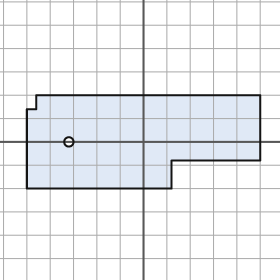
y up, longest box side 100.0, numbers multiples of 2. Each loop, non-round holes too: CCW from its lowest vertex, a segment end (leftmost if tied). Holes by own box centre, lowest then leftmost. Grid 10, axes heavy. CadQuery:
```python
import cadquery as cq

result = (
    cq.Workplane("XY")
    .moveTo(-50.0, -20.0)
    .lineTo(12.0, -20.0)
    .lineTo(12.0, -8.0)
    .lineTo(50.0, -8.0)
    .lineTo(50.0, 20.0)
    .lineTo(-46.0, 20.0)
    .lineTo(-46.0, 14.0)
    .lineTo(-50.0, 14.0)
    .close()
    .moveTo(-32.0, 0.0)
    .circle(2.0)
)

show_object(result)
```